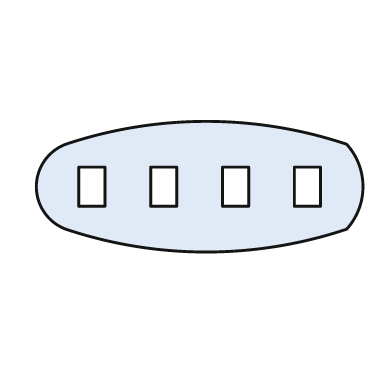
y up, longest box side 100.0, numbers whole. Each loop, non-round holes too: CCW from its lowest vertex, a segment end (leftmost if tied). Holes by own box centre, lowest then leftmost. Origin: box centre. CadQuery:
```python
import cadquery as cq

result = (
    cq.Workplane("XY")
    .moveTo(-41.0, -13.0)
    .threePointArc((2.0, -20.0), (45.0, -13.0))
    .threePointArc((50.0, 0.0), (45.0, 13.0))
    .threePointArc((2.0, 20.0), (-41.0, 13.0))
    .threePointArc((-50.0, 0.0), (-41.0, -13.0))
    .close()
    .moveTo(-37.0, -6.0)
    .lineTo(-29.0, -6.0)
    .lineTo(-29.0, 6.0)
    .lineTo(-37.0, 6.0)
    .close()
    .moveTo(-15.0, -6.0)
    .lineTo(-7.0, -6.0)
    .lineTo(-7.0, 6.0)
    .lineTo(-15.0, 6.0)
    .close()
    .moveTo(7.0, -6.0)
    .lineTo(15.0, -6.0)
    .lineTo(15.0, 6.0)
    .lineTo(7.0, 6.0)
    .close()
    .moveTo(29.0, -6.0)
    .lineTo(37.0, -6.0)
    .lineTo(37.0, 6.0)
    .lineTo(29.0, 6.0)
    .close()
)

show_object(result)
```